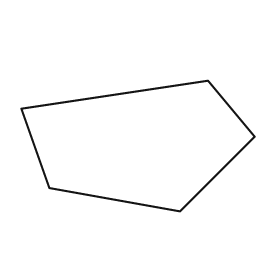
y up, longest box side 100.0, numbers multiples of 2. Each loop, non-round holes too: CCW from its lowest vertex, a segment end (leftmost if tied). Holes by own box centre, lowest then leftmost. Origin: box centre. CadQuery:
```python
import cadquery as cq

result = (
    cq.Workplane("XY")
    .moveTo(18.0, -28.0)
    .lineTo(50.0, 4.0)
    .lineTo(30.0, 28.0)
    .lineTo(-50.0, 16.0)
    .lineTo(-38.0, -18.0)
    .close()
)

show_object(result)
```